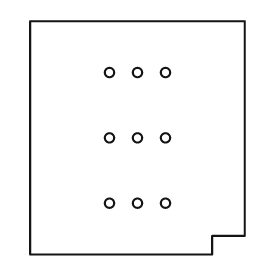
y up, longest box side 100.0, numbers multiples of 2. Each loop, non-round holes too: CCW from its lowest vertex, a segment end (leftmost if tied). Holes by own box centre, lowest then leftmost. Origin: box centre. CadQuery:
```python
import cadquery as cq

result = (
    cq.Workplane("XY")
    .moveTo(-46.0, -50.0)
    .lineTo(32.0, -50.0)
    .lineTo(32.0, -42.0)
    .lineTo(46.0, -42.0)
    .lineTo(46.0, 50.0)
    .lineTo(-46.0, 50.0)
    .close()
    .moveTo(-12.0, -28.0)
    .circle(2.0)
    .moveTo(0.0, -28.0)
    .circle(2.0)
    .moveTo(12.0, -28.0)
    .circle(2.0)
    .moveTo(-12.0, 0.0)
    .circle(2.0)
    .moveTo(0.0, 0.0)
    .circle(2.0)
    .moveTo(12.0, 0.0)
    .circle(2.0)
    .moveTo(-12.0, 28.0)
    .circle(2.0)
    .moveTo(0.0, 28.0)
    .circle(2.0)
    .moveTo(12.0, 28.0)
    .circle(2.0)
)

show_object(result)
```